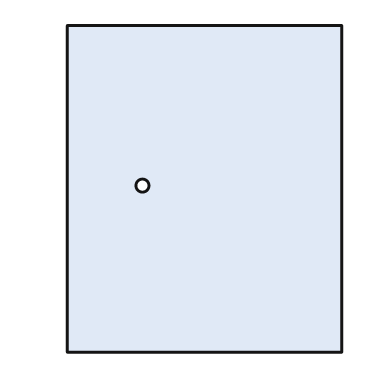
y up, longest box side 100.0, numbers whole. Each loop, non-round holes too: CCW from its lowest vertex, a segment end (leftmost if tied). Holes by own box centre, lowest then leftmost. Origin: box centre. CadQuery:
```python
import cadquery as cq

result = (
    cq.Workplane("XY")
    .moveTo(-42.0, -50.0)
    .lineTo(42.0, -50.0)
    .lineTo(42.0, 50.0)
    .lineTo(-42.0, 50.0)
    .close()
    .moveTo(-19.0, 1.0)
    .circle(2.0)
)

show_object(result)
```